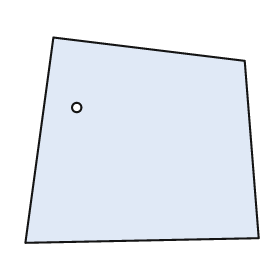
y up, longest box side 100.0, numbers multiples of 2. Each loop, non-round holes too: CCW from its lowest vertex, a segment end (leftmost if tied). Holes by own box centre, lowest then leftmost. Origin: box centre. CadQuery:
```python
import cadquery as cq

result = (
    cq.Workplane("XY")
    .moveTo(-50.0, -44.0)
    .lineTo(50.0, -42.0)
    .lineTo(44.0, 34.0)
    .lineTo(-38.0, 44.0)
    .close()
    .moveTo(-28.0, 14.0)
    .circle(2.0)
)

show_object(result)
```